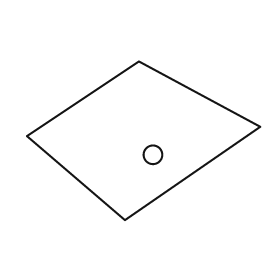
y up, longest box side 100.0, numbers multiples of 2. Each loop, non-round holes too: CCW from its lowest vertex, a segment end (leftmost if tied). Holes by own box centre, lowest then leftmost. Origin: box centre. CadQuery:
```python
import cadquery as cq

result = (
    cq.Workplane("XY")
    .moveTo(-8.0, -34.0)
    .lineTo(50.0, 6.0)
    .lineTo(-2.0, 34.0)
    .lineTo(-50.0, 2.0)
    .close()
    .moveTo(4.0, -6.0)
    .circle(4.0)
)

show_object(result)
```